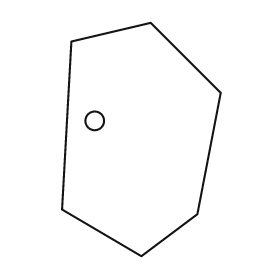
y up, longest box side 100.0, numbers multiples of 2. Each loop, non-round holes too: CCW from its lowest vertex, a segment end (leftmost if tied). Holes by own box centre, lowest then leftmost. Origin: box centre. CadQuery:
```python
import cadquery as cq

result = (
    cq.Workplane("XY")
    .moveTo(0.0, -50.0)
    .lineTo(24.0, -32.0)
    .lineTo(34.0, 20.0)
    .lineTo(4.0, 50.0)
    .lineTo(-30.0, 42.0)
    .lineTo(-34.0, -30.0)
    .close()
    .moveTo(-20.0, 8.0)
    .circle(4.0)
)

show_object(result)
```